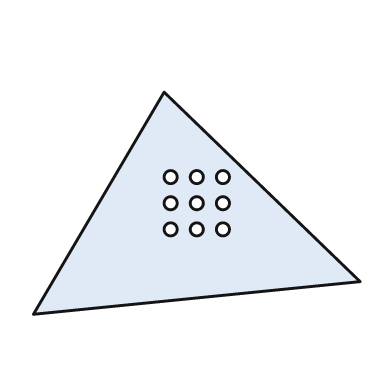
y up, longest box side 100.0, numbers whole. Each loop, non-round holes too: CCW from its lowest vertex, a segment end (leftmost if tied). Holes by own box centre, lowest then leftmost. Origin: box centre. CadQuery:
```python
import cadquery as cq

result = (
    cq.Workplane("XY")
    .moveTo(-50.0, -34.0)
    .lineTo(50.0, -24.0)
    .lineTo(-10.0, 34.0)
    .close()
    .moveTo(-8.0, -8.0)
    .circle(2.0)
    .moveTo(0.0, -8.0)
    .circle(2.0)
    .moveTo(8.0, -8.0)
    .circle(2.0)
    .moveTo(-8.0, 0.0)
    .circle(2.0)
    .moveTo(0.0, 0.0)
    .circle(2.0)
    .moveTo(8.0, 0.0)
    .circle(2.0)
    .moveTo(-8.0, 8.0)
    .circle(2.0)
    .moveTo(0.0, 8.0)
    .circle(2.0)
    .moveTo(8.0, 8.0)
    .circle(2.0)
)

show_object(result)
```